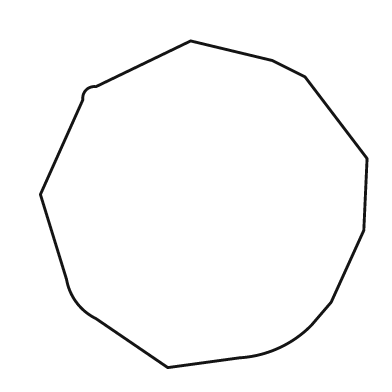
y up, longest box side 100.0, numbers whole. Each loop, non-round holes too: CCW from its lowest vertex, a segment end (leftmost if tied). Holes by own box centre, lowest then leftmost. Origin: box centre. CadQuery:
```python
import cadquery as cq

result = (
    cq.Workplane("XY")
    .moveTo(-11.0, -50.0)
    .lineTo(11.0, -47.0)
    .threePointArc((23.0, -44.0), (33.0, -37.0))
    .lineTo(39.0, -30.0)
    .lineTo(49.0, -8.0)
    .lineTo(50.0, 14.0)
    .lineTo(31.0, 39.0)
    .lineTo(21.0, 44.0)
    .lineTo(-4.0, 50.0)
    .lineTo(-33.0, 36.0)
    .threePointArc((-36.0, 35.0), (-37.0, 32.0))
    .lineTo(-50.0, 3.0)
    .lineTo(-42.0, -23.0)
    .threePointArc((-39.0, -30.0), (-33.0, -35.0))
    .close()
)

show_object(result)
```